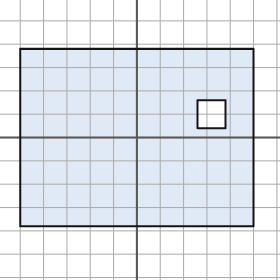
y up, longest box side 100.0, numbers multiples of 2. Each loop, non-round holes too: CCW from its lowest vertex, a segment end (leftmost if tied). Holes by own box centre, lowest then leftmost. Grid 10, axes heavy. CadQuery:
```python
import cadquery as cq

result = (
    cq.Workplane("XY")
    .moveTo(-50.0, -38.0)
    .lineTo(50.0, -38.0)
    .lineTo(50.0, 38.0)
    .lineTo(-50.0, 38.0)
    .close()
    .moveTo(26.0, 4.0)
    .lineTo(38.0, 4.0)
    .lineTo(38.0, 16.0)
    .lineTo(26.0, 16.0)
    .close()
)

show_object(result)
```